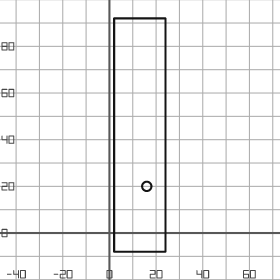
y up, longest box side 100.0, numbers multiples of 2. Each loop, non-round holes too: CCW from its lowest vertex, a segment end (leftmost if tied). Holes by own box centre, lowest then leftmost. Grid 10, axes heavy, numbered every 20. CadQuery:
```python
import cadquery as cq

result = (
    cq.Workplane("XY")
    .moveTo(2.0, -8.0)
    .lineTo(24.0, -8.0)
    .lineTo(24.0, 92.0)
    .lineTo(2.0, 92.0)
    .close()
    .moveTo(16.0, 20.0)
    .circle(2.0)
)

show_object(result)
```